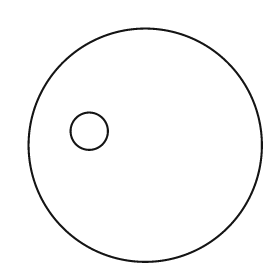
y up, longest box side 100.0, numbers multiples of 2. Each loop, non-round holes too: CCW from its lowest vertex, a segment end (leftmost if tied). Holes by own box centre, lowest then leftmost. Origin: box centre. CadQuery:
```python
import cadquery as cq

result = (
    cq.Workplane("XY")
    .moveTo(0.0, 0.0)
    .circle(50.0)
    .moveTo(-24.0, 6.0)
    .circle(8.0)
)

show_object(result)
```